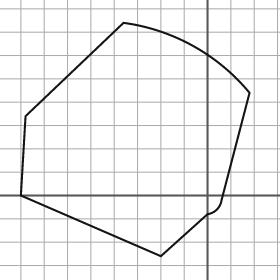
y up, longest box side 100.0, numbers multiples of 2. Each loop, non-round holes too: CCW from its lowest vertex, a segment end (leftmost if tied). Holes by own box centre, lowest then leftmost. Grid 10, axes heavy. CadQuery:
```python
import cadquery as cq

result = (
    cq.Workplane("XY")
    .moveTo(-20.0, -26.0)
    .lineTo(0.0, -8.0)
    .threePointArc((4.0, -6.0), (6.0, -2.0))
    .lineTo(18.0, 44.0)
    .threePointArc((-6.0, 64.0), (-36.0, 74.0))
    .lineTo(-78.0, 34.0)
    .lineTo(-80.0, 0.0)
    .close()
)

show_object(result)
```